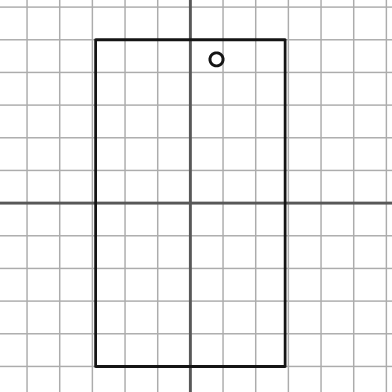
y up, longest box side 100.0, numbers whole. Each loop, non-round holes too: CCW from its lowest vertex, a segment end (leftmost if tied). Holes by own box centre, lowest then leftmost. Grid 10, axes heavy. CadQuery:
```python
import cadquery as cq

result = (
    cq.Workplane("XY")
    .moveTo(-29.0, -50.0)
    .lineTo(29.0, -50.0)
    .lineTo(29.0, 50.0)
    .lineTo(-29.0, 50.0)
    .close()
    .moveTo(8.0, 44.0)
    .circle(2.0)
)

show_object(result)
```